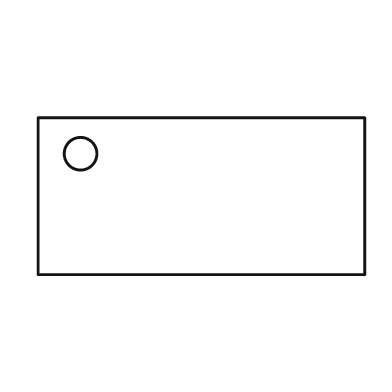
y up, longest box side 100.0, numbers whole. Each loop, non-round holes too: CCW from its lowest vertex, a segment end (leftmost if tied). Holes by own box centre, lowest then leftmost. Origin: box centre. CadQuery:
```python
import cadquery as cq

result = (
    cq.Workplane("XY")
    .moveTo(-50.0, -24.0)
    .lineTo(50.0, -24.0)
    .lineTo(50.0, 24.0)
    .lineTo(-50.0, 24.0)
    .close()
    .moveTo(-37.0, 13.0)
    .circle(5.0)
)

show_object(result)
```